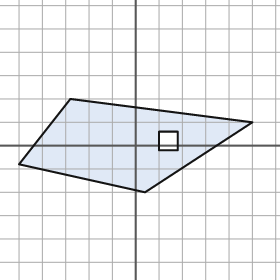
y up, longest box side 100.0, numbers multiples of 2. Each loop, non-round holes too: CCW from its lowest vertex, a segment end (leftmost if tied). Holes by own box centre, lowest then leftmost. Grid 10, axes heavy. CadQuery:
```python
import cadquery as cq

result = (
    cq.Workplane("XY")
    .moveTo(4.0, -20.0)
    .lineTo(50.0, 10.0)
    .lineTo(-28.0, 20.0)
    .lineTo(-50.0, -8.0)
    .close()
    .moveTo(10.0, -2.0)
    .lineTo(18.0, -2.0)
    .lineTo(18.0, 6.0)
    .lineTo(10.0, 6.0)
    .close()
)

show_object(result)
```